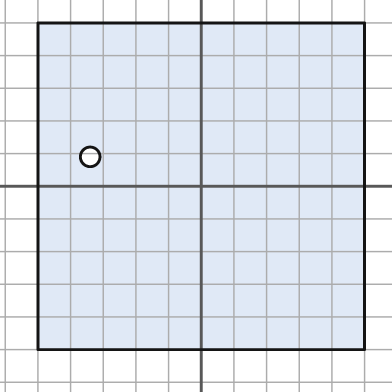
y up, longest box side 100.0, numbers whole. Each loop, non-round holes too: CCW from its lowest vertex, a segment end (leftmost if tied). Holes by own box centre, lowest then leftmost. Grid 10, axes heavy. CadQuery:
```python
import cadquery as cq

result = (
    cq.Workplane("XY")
    .moveTo(-50.0, -50.0)
    .lineTo(50.0, -50.0)
    .lineTo(50.0, 50.0)
    .lineTo(-50.0, 50.0)
    .close()
    .moveTo(-34.0, 9.0)
    .circle(3.0)
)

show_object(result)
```